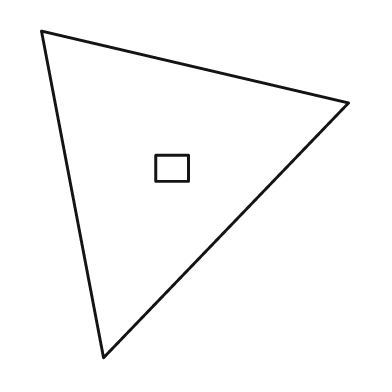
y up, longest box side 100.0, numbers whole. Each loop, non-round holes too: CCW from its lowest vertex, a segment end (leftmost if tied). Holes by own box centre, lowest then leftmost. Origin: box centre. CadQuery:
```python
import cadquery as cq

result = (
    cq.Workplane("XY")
    .moveTo(-28.0, -50.0)
    .lineTo(47.0, 28.0)
    .lineTo(-47.0, 50.0)
    .close()
    .moveTo(-12.0, 4.0)
    .lineTo(-2.0, 4.0)
    .lineTo(-2.0, 12.0)
    .lineTo(-12.0, 12.0)
    .close()
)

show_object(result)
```